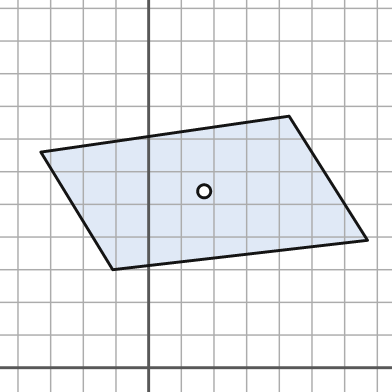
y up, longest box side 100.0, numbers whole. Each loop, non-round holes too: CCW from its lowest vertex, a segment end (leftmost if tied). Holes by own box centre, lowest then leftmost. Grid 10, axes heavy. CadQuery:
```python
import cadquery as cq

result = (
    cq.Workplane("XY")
    .moveTo(-11.0, 30.0)
    .lineTo(67.0, 39.0)
    .lineTo(43.0, 77.0)
    .lineTo(-33.0, 66.0)
    .close()
    .moveTo(17.0, 54.0)
    .circle(2.0)
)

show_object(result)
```